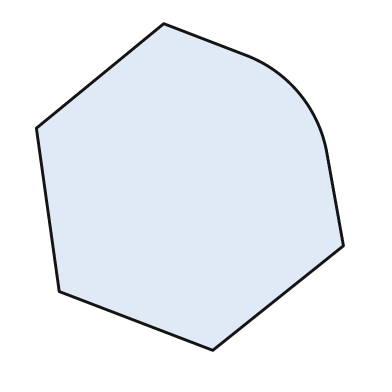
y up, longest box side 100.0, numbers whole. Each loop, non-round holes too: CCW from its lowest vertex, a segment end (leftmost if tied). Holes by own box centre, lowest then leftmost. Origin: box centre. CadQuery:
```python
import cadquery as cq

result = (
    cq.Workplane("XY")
    .moveTo(7.0, -50.0)
    .lineTo(47.0, -18.0)
    .lineTo(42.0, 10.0)
    .threePointArc((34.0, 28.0), (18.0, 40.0))
    .lineTo(-8.0, 50.0)
    .lineTo(-47.0, 18.0)
    .lineTo(-40.0, -32.0)
    .close()
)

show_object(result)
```